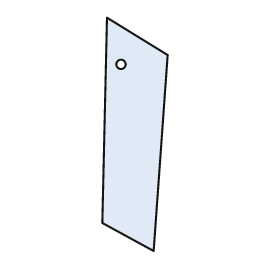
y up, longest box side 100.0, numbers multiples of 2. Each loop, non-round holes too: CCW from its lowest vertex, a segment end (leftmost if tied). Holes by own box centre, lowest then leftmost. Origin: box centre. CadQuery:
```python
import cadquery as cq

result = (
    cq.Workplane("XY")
    .moveTo(8.0, -50.0)
    .lineTo(14.0, 34.0)
    .lineTo(-12.0, 50.0)
    .lineTo(-14.0, -38.0)
    .close()
    .moveTo(-6.0, 30.0)
    .circle(2.0)
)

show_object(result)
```